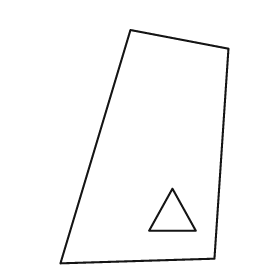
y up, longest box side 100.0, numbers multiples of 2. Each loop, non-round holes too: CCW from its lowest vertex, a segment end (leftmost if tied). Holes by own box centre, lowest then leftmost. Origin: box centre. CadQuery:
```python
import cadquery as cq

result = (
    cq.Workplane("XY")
    .moveTo(-36.0, -50.0)
    .lineTo(30.0, -48.0)
    .lineTo(36.0, 42.0)
    .lineTo(-6.0, 50.0)
    .close()
    .moveTo(2.0, -36.0)
    .lineTo(22.0, -36.0)
    .lineTo(12.0, -18.0)
    .close()
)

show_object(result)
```